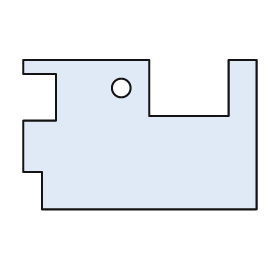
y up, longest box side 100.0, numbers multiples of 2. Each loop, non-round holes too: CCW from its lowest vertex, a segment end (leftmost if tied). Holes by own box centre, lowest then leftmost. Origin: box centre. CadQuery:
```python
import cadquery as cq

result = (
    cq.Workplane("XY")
    .moveTo(-42.0, -32.0)
    .lineTo(50.0, -32.0)
    .lineTo(50.0, 32.0)
    .lineTo(38.0, 32.0)
    .lineTo(38.0, 8.0)
    .lineTo(4.0, 8.0)
    .lineTo(4.0, 32.0)
    .lineTo(-50.0, 32.0)
    .lineTo(-50.0, 26.0)
    .lineTo(-36.0, 26.0)
    .lineTo(-36.0, 6.0)
    .lineTo(-50.0, 6.0)
    .lineTo(-50.0, -16.0)
    .lineTo(-42.0, -16.0)
    .close()
    .moveTo(-8.0, 20.0)
    .circle(4.0)
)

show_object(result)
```